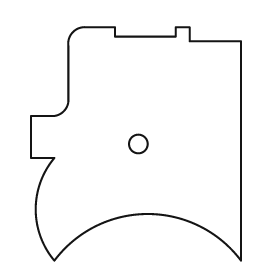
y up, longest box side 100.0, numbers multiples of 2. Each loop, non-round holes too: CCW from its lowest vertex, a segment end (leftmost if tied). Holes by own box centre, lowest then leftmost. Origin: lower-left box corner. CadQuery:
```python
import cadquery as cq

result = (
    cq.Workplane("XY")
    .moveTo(10.0, 0.0)
    .threePointArc((50.0, 20.0), (90.0, 0.0))
    .lineTo(90.0, 94.0)
    .lineTo(68.0, 94.0)
    .lineTo(68.0, 100.0)
    .lineTo(62.0, 100.0)
    .lineTo(62.0, 96.0)
    .lineTo(36.0, 96.0)
    .lineTo(36.0, 100.0)
    .lineTo(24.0, 100.0)
    .threePointArc((18.0, 98.0), (16.0, 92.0))
    .lineTo(16.0, 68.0)
    .threePointArc((14.0, 64.0), (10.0, 62.0))
    .lineTo(0.0, 62.0)
    .lineTo(0.0, 44.0)
    .lineTo(10.0, 44.0)
    .threePointArc((2.0, 22.0), (10.0, 0.0))
    .close()
    .moveTo(46.0, 50.0)
    .circle(4.0)
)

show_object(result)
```